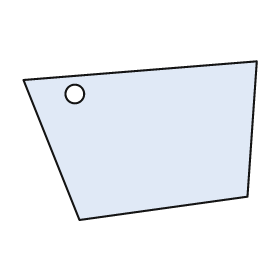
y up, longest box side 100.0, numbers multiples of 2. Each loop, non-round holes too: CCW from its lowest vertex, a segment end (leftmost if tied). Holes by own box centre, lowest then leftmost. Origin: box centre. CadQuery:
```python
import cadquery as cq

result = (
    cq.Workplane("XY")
    .moveTo(-26.0, -34.0)
    .lineTo(46.0, -24.0)
    .lineTo(50.0, 34.0)
    .lineTo(-50.0, 26.0)
    .close()
    .moveTo(-28.0, 20.0)
    .circle(4.0)
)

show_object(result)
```